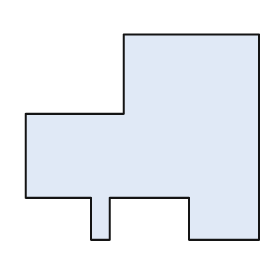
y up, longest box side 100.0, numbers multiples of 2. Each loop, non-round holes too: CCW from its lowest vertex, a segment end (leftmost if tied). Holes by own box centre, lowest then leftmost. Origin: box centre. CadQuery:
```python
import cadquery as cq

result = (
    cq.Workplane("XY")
    .moveTo(-22.0, -44.0)
    .lineTo(-14.0, -44.0)
    .lineTo(-14.0, -26.0)
    .lineTo(20.0, -26.0)
    .lineTo(20.0, -44.0)
    .lineTo(50.0, -44.0)
    .lineTo(50.0, 44.0)
    .lineTo(-8.0, 44.0)
    .lineTo(-8.0, 10.0)
    .lineTo(-50.0, 10.0)
    .lineTo(-50.0, -26.0)
    .lineTo(-22.0, -26.0)
    .close()
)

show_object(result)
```